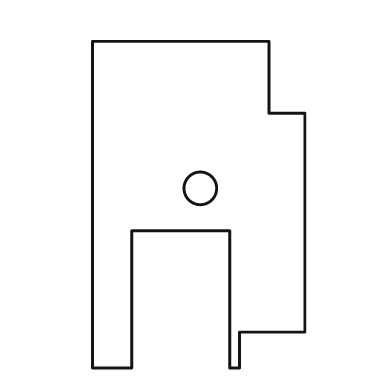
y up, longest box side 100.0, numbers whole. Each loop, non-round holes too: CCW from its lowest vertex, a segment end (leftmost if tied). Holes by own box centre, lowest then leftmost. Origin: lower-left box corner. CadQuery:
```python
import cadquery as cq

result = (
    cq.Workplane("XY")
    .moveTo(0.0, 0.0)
    .lineTo(12.0, 0.0)
    .lineTo(12.0, 42.0)
    .lineTo(42.0, 42.0)
    .lineTo(42.0, 0.0)
    .lineTo(45.0, 0.0)
    .lineTo(45.0, 11.0)
    .lineTo(65.0, 11.0)
    .lineTo(65.0, 78.0)
    .lineTo(54.0, 78.0)
    .lineTo(54.0, 100.0)
    .lineTo(0.0, 100.0)
    .close()
    .moveTo(33.0, 55.0)
    .circle(5.0)
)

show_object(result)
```